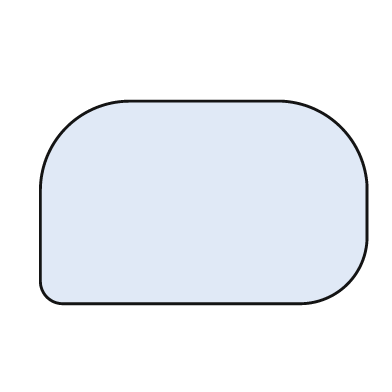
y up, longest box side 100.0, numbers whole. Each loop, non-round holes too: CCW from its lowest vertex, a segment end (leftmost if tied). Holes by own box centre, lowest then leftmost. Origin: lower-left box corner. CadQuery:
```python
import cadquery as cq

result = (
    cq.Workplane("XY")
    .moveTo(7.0, 0.0)
    .lineTo(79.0, 0.0)
    .threePointArc((94.0, 6.0), (100.0, 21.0))
    .lineTo(100.0, 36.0)
    .threePointArc((92.0, 54.0), (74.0, 62.0))
    .lineTo(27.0, 62.0)
    .threePointArc((8.0, 54.0), (0.0, 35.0))
    .lineTo(0.0, 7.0)
    .threePointArc((2.0, 2.0), (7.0, 0.0))
    .close()
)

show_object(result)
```